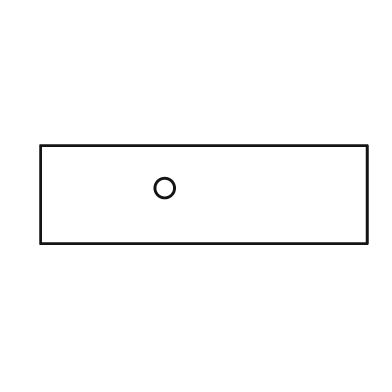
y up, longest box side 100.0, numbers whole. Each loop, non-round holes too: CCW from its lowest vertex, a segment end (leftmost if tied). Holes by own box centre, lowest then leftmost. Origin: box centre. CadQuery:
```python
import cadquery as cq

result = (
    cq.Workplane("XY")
    .moveTo(-50.0, -15.0)
    .lineTo(50.0, -15.0)
    .lineTo(50.0, 15.0)
    .lineTo(-50.0, 15.0)
    .close()
    .moveTo(-12.0, 2.0)
    .circle(3.0)
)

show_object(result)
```